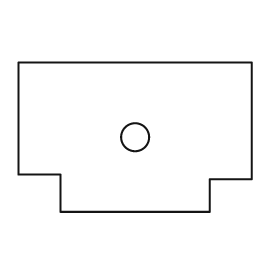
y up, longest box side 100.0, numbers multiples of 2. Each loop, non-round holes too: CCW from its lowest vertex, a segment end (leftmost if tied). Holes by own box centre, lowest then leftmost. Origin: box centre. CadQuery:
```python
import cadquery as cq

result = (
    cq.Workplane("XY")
    .moveTo(-32.0, -32.0)
    .lineTo(32.0, -32.0)
    .lineTo(32.0, -18.0)
    .lineTo(50.0, -18.0)
    .lineTo(50.0, 32.0)
    .lineTo(-50.0, 32.0)
    .lineTo(-50.0, -16.0)
    .lineTo(-32.0, -16.0)
    .close()
    .moveTo(0.0, 0.0)
    .circle(6.0)
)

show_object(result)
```